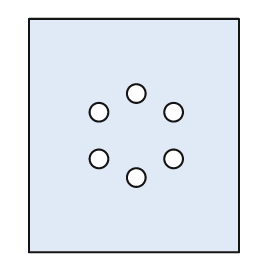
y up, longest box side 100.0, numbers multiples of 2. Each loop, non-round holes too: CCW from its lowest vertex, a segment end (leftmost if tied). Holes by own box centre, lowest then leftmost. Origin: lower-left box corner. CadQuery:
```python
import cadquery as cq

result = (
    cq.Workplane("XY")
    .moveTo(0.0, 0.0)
    .lineTo(90.0, 0.0)
    .lineTo(90.0, 100.0)
    .lineTo(0.0, 100.0)
    .close()
    .moveTo(46.0, 32.0)
    .circle(4.0)
    .moveTo(30.0, 40.0)
    .circle(4.0)
    .moveTo(62.0, 40.0)
    .circle(4.0)
    .moveTo(30.0, 60.0)
    .circle(4.0)
    .moveTo(62.0, 60.0)
    .circle(4.0)
    .moveTo(46.0, 68.0)
    .circle(4.0)
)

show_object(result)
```